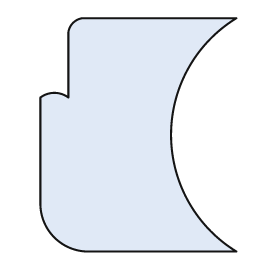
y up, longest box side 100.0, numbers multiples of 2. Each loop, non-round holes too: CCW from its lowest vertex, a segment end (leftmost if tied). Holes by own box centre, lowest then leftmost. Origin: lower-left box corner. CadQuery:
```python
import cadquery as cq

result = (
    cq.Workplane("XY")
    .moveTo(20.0, 0.0)
    .lineTo(84.0, 0.0)
    .threePointArc((56.0, 50.0), (84.0, 100.0))
    .lineTo(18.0, 100.0)
    .threePointArc((14.0, 98.0), (12.0, 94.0))
    .lineTo(12.0, 66.0)
    .threePointArc((6.0, 68.0), (0.0, 66.0))
    .lineTo(0.0, 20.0)
    .threePointArc((6.0, 6.0), (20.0, 0.0))
    .close()
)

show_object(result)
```